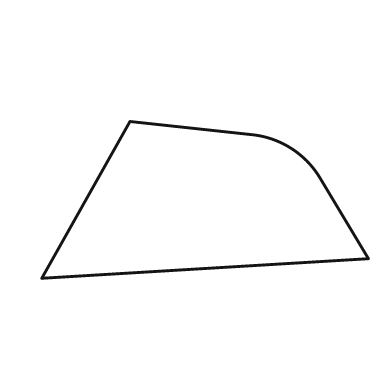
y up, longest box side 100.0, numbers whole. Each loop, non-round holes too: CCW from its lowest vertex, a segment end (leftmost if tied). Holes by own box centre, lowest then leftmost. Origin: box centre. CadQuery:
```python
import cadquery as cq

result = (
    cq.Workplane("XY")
    .moveTo(-50.0, -24.0)
    .lineTo(50.0, -18.0)
    .lineTo(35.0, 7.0)
    .threePointArc((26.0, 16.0), (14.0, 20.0))
    .lineTo(-23.0, 24.0)
    .close()
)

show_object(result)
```